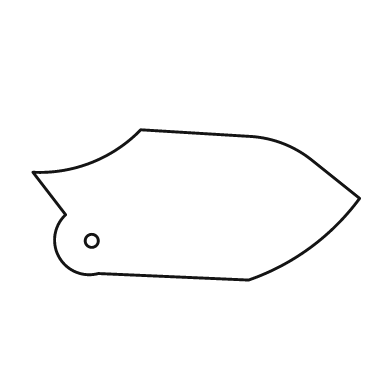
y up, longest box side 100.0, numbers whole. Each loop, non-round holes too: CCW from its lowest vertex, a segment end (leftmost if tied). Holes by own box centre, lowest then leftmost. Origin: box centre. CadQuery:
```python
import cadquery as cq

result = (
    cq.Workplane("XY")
    .moveTo(16.0, -23.0)
    .threePointArc((35.0, -13.0), (50.0, 2.0))
    .lineTo(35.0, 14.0)
    .threePointArc((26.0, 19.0), (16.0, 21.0))
    .lineTo(-17.0, 23.0)
    .threePointArc((-32.0, 13.0), (-50.0, 10.0))
    .lineTo(-40.0, -3.0)
    .threePointArc((-42.0, -16.0), (-30.0, -21.0))
    .close()
    .moveTo(-32.0, -11.0)
    .circle(2.0)
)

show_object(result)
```